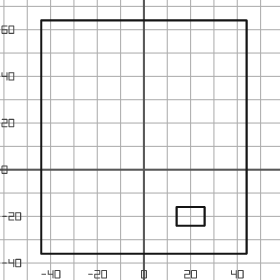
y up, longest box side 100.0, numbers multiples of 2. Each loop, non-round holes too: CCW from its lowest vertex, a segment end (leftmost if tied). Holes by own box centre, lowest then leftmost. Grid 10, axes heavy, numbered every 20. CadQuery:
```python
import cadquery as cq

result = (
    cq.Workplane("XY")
    .moveTo(-44.0, -36.0)
    .lineTo(44.0, -36.0)
    .lineTo(44.0, 64.0)
    .lineTo(-44.0, 64.0)
    .close()
    .moveTo(14.0, -24.0)
    .lineTo(26.0, -24.0)
    .lineTo(26.0, -16.0)
    .lineTo(14.0, -16.0)
    .close()
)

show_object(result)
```